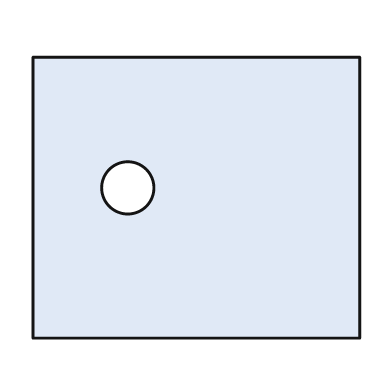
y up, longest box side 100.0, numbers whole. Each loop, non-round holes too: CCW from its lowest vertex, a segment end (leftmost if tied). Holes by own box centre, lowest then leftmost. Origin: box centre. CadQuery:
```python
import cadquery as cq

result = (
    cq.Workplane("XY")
    .moveTo(-50.0, -43.0)
    .lineTo(50.0, -43.0)
    .lineTo(50.0, 43.0)
    .lineTo(-50.0, 43.0)
    .close()
    .moveTo(-21.0, 3.0)
    .circle(8.0)
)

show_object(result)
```